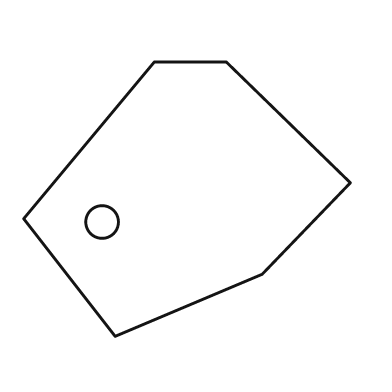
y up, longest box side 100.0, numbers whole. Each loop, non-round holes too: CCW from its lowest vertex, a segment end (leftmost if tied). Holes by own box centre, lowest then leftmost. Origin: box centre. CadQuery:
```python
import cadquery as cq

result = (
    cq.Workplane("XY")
    .moveTo(-22.0, -42.0)
    .lineTo(23.0, -23.0)
    .lineTo(50.0, 5.0)
    .lineTo(12.0, 42.0)
    .lineTo(-10.0, 42.0)
    .lineTo(-50.0, -6.0)
    .close()
    .moveTo(-26.0, -7.0)
    .circle(5.0)
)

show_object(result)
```